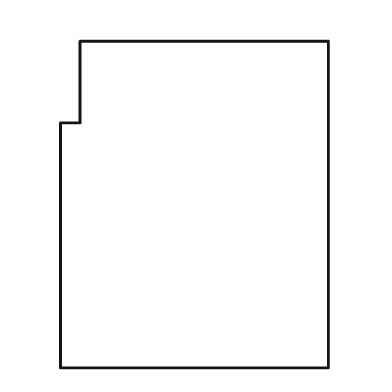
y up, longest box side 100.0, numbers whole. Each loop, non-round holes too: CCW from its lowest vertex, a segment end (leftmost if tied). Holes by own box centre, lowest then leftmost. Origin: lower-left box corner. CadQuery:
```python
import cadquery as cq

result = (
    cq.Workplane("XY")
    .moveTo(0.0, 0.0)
    .lineTo(82.0, 0.0)
    .lineTo(82.0, 100.0)
    .lineTo(6.0, 100.0)
    .lineTo(6.0, 75.0)
    .lineTo(0.0, 75.0)
    .close()
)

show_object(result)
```